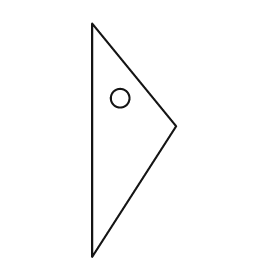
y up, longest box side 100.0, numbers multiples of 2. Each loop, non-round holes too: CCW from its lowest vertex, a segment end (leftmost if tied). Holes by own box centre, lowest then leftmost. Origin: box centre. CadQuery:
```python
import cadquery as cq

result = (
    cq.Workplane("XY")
    .moveTo(-18.0, -50.0)
    .lineTo(18.0, 6.0)
    .lineTo(-18.0, 50.0)
    .close()
    .moveTo(-6.0, 18.0)
    .circle(4.0)
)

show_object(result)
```